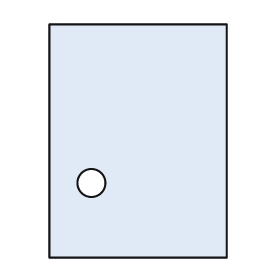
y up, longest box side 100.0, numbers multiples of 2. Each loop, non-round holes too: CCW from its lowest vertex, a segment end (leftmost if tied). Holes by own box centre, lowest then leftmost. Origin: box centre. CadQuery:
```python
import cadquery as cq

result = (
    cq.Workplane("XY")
    .moveTo(-38.0, -50.0)
    .lineTo(38.0, -50.0)
    .lineTo(38.0, 50.0)
    .lineTo(-38.0, 50.0)
    .close()
    .moveTo(-20.0, -18.0)
    .circle(6.0)
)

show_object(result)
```